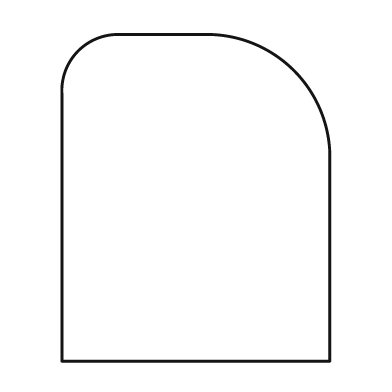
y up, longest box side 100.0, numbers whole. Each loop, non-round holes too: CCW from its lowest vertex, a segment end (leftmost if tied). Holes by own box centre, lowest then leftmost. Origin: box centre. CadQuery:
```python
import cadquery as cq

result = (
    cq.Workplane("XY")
    .moveTo(-41.0, -50.0)
    .lineTo(41.0, -50.0)
    .lineTo(41.0, 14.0)
    .threePointArc((30.0, 39.0), (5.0, 50.0))
    .lineTo(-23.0, 50.0)
    .threePointArc((-36.0, 45.0), (-41.0, 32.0))
    .close()
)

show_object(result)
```